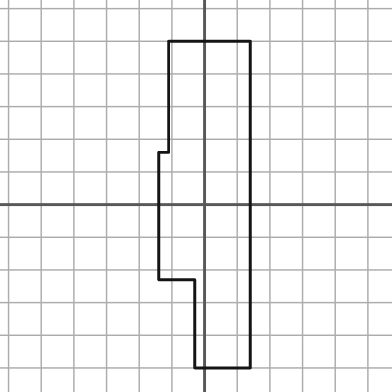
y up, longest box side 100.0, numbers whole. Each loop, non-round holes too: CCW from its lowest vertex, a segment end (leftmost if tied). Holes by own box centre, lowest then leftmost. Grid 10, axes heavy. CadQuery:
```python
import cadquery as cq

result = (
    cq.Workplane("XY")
    .moveTo(-3.0, -50.0)
    .lineTo(14.0, -50.0)
    .lineTo(14.0, 50.0)
    .lineTo(-11.0, 50.0)
    .lineTo(-11.0, 16.0)
    .lineTo(-14.0, 16.0)
    .lineTo(-14.0, -23.0)
    .lineTo(-3.0, -23.0)
    .close()
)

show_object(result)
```